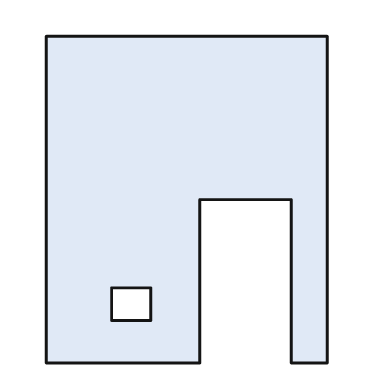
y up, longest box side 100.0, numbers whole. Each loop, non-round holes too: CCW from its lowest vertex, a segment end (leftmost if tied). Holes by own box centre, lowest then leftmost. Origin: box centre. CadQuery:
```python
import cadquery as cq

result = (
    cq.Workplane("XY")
    .moveTo(-43.0, -50.0)
    .lineTo(4.0, -50.0)
    .lineTo(4.0, 0.0)
    .lineTo(32.0, 0.0)
    .lineTo(32.0, -50.0)
    .lineTo(43.0, -50.0)
    .lineTo(43.0, 50.0)
    .lineTo(-43.0, 50.0)
    .close()
    .moveTo(-23.0, -37.0)
    .lineTo(-11.0, -37.0)
    .lineTo(-11.0, -27.0)
    .lineTo(-23.0, -27.0)
    .close()
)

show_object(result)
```